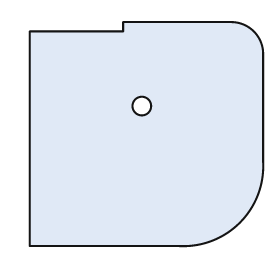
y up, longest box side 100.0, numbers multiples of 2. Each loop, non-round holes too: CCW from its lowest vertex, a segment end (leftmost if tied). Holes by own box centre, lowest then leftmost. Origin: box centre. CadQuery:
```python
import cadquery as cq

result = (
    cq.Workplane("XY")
    .moveTo(-50.0, -48.0)
    .lineTo(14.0, -48.0)
    .threePointArc((40.0, -38.0), (50.0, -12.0))
    .lineTo(50.0, 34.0)
    .threePointArc((46.0, 44.0), (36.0, 48.0))
    .lineTo(-10.0, 48.0)
    .lineTo(-10.0, 44.0)
    .lineTo(-50.0, 44.0)
    .close()
    .moveTo(-2.0, 12.0)
    .circle(4.0)
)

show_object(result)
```